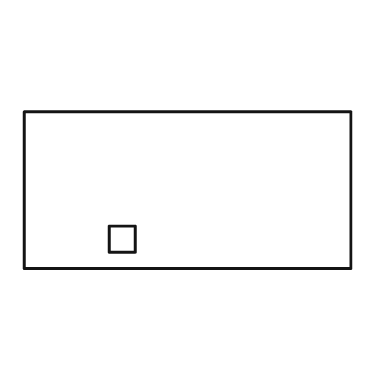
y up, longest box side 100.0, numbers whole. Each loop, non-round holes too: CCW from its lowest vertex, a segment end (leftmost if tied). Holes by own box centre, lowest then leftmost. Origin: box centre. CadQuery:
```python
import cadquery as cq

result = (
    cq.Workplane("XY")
    .moveTo(-50.0, -24.0)
    .lineTo(50.0, -24.0)
    .lineTo(50.0, 24.0)
    .lineTo(-50.0, 24.0)
    .close()
    .moveTo(-24.0, -19.0)
    .lineTo(-16.0, -19.0)
    .lineTo(-16.0, -11.0)
    .lineTo(-24.0, -11.0)
    .close()
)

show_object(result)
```